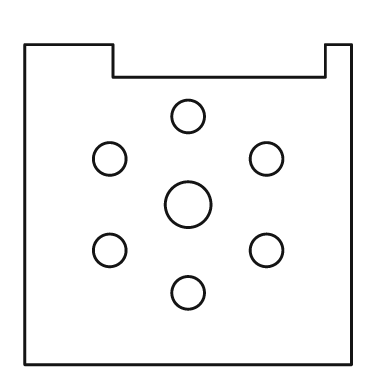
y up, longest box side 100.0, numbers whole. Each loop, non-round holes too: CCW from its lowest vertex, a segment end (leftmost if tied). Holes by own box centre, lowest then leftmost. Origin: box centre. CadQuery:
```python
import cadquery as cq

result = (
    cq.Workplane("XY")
    .moveTo(-50.0, -49.0)
    .lineTo(50.0, -49.0)
    .lineTo(50.0, 49.0)
    .lineTo(42.0, 49.0)
    .lineTo(42.0, 39.0)
    .lineTo(-23.0, 39.0)
    .lineTo(-23.0, 49.0)
    .lineTo(-50.0, 49.0)
    .close()
    .moveTo(0.0, -27.0)
    .circle(5.0)
    .moveTo(-24.0, -14.0)
    .circle(5.0)
    .moveTo(24.0, -14.0)
    .circle(5.0)
    .moveTo(0.0, 0.0)
    .circle(7.0)
    .moveTo(-24.0, 14.0)
    .circle(5.0)
    .moveTo(24.0, 14.0)
    .circle(5.0)
    .moveTo(0.0, 27.0)
    .circle(5.0)
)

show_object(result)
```